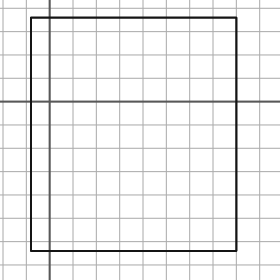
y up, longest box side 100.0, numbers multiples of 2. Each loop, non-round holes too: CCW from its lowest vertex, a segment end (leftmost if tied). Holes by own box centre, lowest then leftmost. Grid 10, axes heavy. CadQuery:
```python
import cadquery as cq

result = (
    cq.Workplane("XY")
    .moveTo(-8.0, -64.0)
    .lineTo(80.0, -64.0)
    .lineTo(80.0, 36.0)
    .lineTo(-8.0, 36.0)
    .close()
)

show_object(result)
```